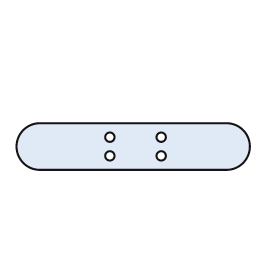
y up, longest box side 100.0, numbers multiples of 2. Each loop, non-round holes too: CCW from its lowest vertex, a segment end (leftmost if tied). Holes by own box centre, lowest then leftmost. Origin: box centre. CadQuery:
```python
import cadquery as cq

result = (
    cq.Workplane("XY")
    .moveTo(-40.0, -10.0)
    .lineTo(40.0, -10.0)
    .threePointArc((50.0, 0.0), (40.0, 10.0))
    .lineTo(-40.0, 10.0)
    .threePointArc((-50.0, 0.0), (-40.0, -10.0))
    .close()
    .moveTo(-10.0, -4.0)
    .circle(2.0)
    .moveTo(12.0, -4.0)
    .circle(2.0)
    .moveTo(-10.0, 4.0)
    .circle(2.0)
    .moveTo(12.0, 4.0)
    .circle(2.0)
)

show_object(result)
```